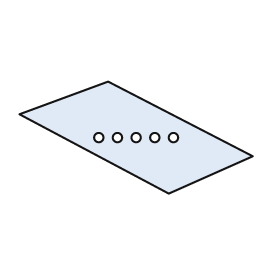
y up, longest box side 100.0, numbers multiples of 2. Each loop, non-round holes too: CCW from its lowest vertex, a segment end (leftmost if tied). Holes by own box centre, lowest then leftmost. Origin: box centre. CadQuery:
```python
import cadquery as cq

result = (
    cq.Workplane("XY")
    .moveTo(14.0, -24.0)
    .lineTo(50.0, -8.0)
    .lineTo(-12.0, 24.0)
    .lineTo(-50.0, 10.0)
    .close()
    .moveTo(-16.0, 0.0)
    .circle(2.0)
    .moveTo(-8.0, 0.0)
    .circle(2.0)
    .moveTo(0.0, 0.0)
    .circle(2.0)
    .moveTo(8.0, 0.0)
    .circle(2.0)
    .moveTo(16.0, 0.0)
    .circle(2.0)
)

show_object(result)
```